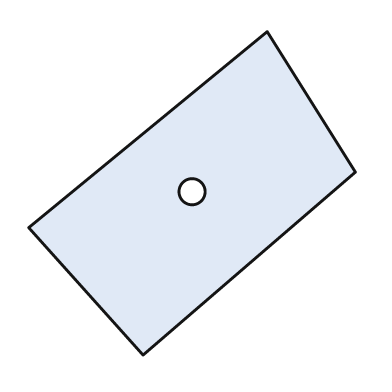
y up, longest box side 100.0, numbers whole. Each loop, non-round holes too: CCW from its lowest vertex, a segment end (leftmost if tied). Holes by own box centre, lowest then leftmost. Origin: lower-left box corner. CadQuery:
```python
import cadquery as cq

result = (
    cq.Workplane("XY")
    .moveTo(35.0, 0.0)
    .lineTo(100.0, 56.0)
    .lineTo(73.0, 99.0)
    .lineTo(0.0, 39.0)
    .close()
    .moveTo(50.0, 50.0)
    .circle(4.0)
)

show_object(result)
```